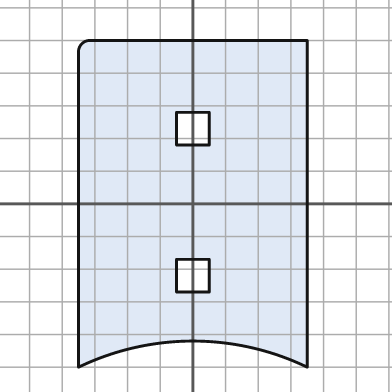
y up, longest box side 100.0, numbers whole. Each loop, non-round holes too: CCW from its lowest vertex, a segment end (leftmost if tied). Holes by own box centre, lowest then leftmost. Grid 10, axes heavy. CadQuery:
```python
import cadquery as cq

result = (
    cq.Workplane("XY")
    .moveTo(-35.0, -50.0)
    .threePointArc((0.0, -42.0), (35.0, -50.0))
    .lineTo(35.0, 50.0)
    .lineTo(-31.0, 50.0)
    .threePointArc((-34.0, 49.0), (-35.0, 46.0))
    .close()
    .moveTo(-5.0, -27.0)
    .lineTo(5.0, -27.0)
    .lineTo(5.0, -17.0)
    .lineTo(-5.0, -17.0)
    .close()
    .moveTo(-5.0, 18.0)
    .lineTo(5.0, 18.0)
    .lineTo(5.0, 28.0)
    .lineTo(-5.0, 28.0)
    .close()
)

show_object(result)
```